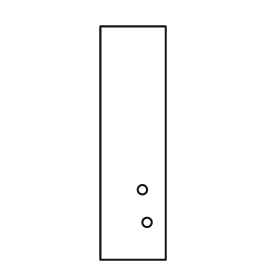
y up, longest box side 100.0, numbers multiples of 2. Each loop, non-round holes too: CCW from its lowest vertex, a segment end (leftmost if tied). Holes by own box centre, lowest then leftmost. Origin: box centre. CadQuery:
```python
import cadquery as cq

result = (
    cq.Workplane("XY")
    .moveTo(-14.0, -50.0)
    .lineTo(14.0, -50.0)
    .lineTo(14.0, 50.0)
    .lineTo(-14.0, 50.0)
    .close()
    .moveTo(6.0, -34.0)
    .circle(2.0)
    .moveTo(4.0, -20.0)
    .circle(2.0)
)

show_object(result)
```